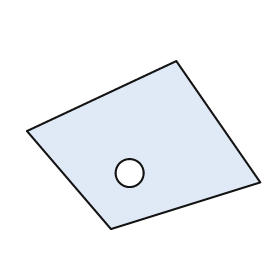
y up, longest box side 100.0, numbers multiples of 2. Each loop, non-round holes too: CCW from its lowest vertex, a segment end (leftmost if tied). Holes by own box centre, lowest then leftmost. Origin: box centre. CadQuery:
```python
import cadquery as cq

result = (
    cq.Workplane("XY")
    .moveTo(-14.0, -36.0)
    .lineTo(50.0, -16.0)
    .lineTo(14.0, 36.0)
    .lineTo(-50.0, 6.0)
    .close()
    .moveTo(-6.0, -12.0)
    .circle(6.0)
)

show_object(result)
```